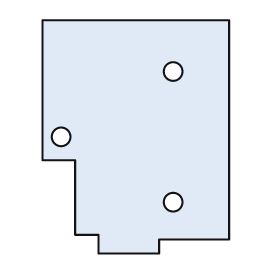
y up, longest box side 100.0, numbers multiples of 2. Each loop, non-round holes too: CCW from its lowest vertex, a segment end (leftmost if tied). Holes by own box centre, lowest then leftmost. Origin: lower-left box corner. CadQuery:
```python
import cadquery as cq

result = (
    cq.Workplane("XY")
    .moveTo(24.0, 0.0)
    .lineTo(50.0, 0.0)
    .lineTo(50.0, 6.0)
    .lineTo(80.0, 6.0)
    .lineTo(80.0, 100.0)
    .lineTo(0.0, 100.0)
    .lineTo(0.0, 40.0)
    .lineTo(14.0, 40.0)
    .lineTo(14.0, 8.0)
    .lineTo(24.0, 8.0)
    .close()
    .moveTo(56.0, 22.0)
    .circle(4.0)
    .moveTo(8.0, 50.0)
    .circle(4.0)
    .moveTo(56.0, 78.0)
    .circle(4.0)
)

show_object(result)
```